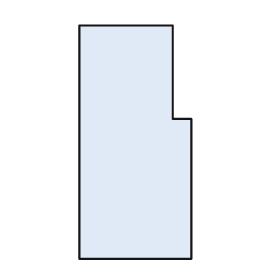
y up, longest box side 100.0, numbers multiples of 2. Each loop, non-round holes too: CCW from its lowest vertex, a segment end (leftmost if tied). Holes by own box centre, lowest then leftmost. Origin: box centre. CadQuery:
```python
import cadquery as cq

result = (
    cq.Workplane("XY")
    .moveTo(-24.0, -50.0)
    .lineTo(24.0, -50.0)
    .lineTo(24.0, 10.0)
    .lineTo(16.0, 10.0)
    .lineTo(16.0, 50.0)
    .lineTo(-24.0, 50.0)
    .close()
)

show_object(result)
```